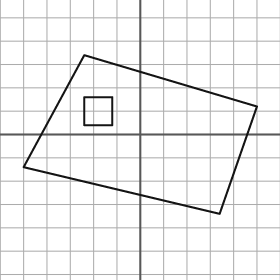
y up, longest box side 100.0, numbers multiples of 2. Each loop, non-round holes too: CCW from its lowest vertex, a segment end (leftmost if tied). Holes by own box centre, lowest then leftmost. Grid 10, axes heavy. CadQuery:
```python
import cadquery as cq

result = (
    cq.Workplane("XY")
    .moveTo(34.0, -34.0)
    .lineTo(50.0, 12.0)
    .lineTo(-24.0, 34.0)
    .lineTo(-50.0, -14.0)
    .close()
    .moveTo(-24.0, 4.0)
    .lineTo(-12.0, 4.0)
    .lineTo(-12.0, 16.0)
    .lineTo(-24.0, 16.0)
    .close()
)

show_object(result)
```